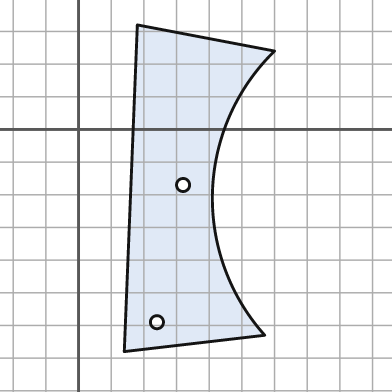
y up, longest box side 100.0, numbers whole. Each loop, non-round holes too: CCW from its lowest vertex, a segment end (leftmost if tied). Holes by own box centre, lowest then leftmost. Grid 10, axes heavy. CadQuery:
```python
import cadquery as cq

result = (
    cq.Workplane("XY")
    .moveTo(14.0, -68.0)
    .lineTo(57.0, -63.0)
    .threePointArc((41.0, -19.0), (60.0, 24.0))
    .lineTo(18.0, 32.0)
    .close()
    .moveTo(24.0, -59.0)
    .circle(2.0)
    .moveTo(32.0, -17.0)
    .circle(2.0)
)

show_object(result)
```